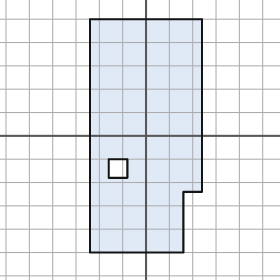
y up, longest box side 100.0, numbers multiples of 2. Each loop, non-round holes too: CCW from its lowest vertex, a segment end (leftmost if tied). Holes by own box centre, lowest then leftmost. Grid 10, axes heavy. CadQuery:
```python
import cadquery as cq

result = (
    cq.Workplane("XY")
    .moveTo(-24.0, -50.0)
    .lineTo(16.0, -50.0)
    .lineTo(16.0, -24.0)
    .lineTo(24.0, -24.0)
    .lineTo(24.0, 50.0)
    .lineTo(-24.0, 50.0)
    .close()
    .moveTo(-16.0, -18.0)
    .lineTo(-8.0, -18.0)
    .lineTo(-8.0, -10.0)
    .lineTo(-16.0, -10.0)
    .close()
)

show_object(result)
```